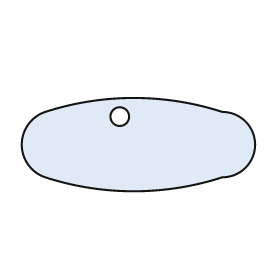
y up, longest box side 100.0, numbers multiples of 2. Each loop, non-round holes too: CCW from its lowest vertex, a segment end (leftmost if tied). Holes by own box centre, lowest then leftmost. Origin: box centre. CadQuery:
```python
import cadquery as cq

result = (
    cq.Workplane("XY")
    .moveTo(-40.0, -14.0)
    .threePointArc((-2.0, -20.0), (36.0, -14.0))
    .threePointArc((50.0, 0.0), (36.0, 14.0))
    .threePointArc((-2.0, 20.0), (-40.0, 14.0))
    .threePointArc((-50.0, 0.0), (-40.0, -14.0))
    .close()
    .moveTo(-8.0, 12.0)
    .circle(4.0)
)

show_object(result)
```